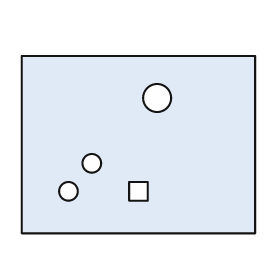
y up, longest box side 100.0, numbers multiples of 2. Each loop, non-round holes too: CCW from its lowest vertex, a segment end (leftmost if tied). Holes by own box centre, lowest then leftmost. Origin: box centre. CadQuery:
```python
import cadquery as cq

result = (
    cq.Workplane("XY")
    .moveTo(-50.0, -38.0)
    .lineTo(50.0, -38.0)
    .lineTo(50.0, 38.0)
    .lineTo(-50.0, 38.0)
    .close()
    .moveTo(-30.0, -20.0)
    .circle(4.0)
    .moveTo(-4.0, -24.0)
    .lineTo(4.0, -24.0)
    .lineTo(4.0, -16.0)
    .lineTo(-4.0, -16.0)
    .close()
    .moveTo(-20.0, -8.0)
    .circle(4.0)
    .moveTo(8.0, 20.0)
    .circle(6.0)
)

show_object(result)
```